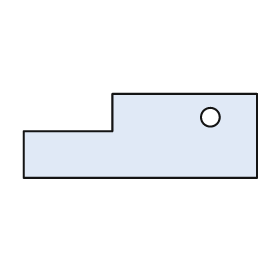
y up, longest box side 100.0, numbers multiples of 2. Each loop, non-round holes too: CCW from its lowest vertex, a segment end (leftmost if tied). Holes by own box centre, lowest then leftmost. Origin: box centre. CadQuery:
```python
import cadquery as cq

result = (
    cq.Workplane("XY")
    .moveTo(-50.0, -18.0)
    .lineTo(50.0, -18.0)
    .lineTo(50.0, 18.0)
    .lineTo(-12.0, 18.0)
    .lineTo(-12.0, 2.0)
    .lineTo(-50.0, 2.0)
    .close()
    .moveTo(30.0, 8.0)
    .circle(4.0)
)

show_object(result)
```